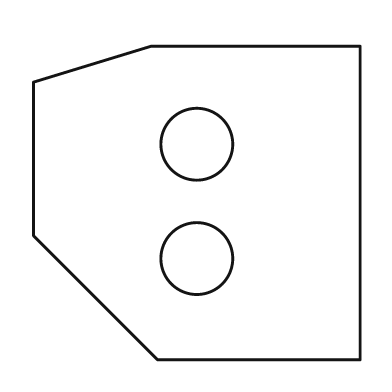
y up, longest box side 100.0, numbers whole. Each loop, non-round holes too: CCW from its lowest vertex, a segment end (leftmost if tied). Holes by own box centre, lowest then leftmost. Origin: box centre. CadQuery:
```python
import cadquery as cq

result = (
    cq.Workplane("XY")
    .moveTo(-12.0, -48.0)
    .lineTo(50.0, -48.0)
    .lineTo(50.0, 48.0)
    .lineTo(-14.0, 48.0)
    .lineTo(-50.0, 37.0)
    .lineTo(-50.0, -10.0)
    .close()
    .moveTo(0.0, -17.0)
    .circle(11.0)
    .moveTo(0.0, 18.0)
    .circle(11.0)
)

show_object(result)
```